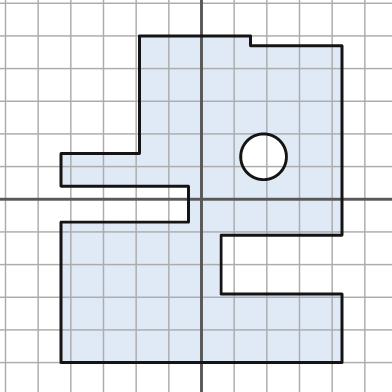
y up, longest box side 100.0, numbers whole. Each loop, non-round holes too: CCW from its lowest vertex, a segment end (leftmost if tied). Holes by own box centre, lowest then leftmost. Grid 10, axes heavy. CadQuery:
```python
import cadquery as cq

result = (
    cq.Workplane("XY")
    .moveTo(-43.0, -50.0)
    .lineTo(43.0, -50.0)
    .lineTo(43.0, -29.0)
    .lineTo(6.0, -29.0)
    .lineTo(6.0, -11.0)
    .lineTo(43.0, -11.0)
    .lineTo(43.0, 47.0)
    .lineTo(15.0, 47.0)
    .lineTo(15.0, 50.0)
    .lineTo(-19.0, 50.0)
    .lineTo(-19.0, 14.0)
    .lineTo(-43.0, 14.0)
    .lineTo(-43.0, 4.0)
    .lineTo(-4.0, 4.0)
    .lineTo(-4.0, -7.0)
    .lineTo(-43.0, -7.0)
    .close()
    .moveTo(19.0, 13.0)
    .circle(7.0)
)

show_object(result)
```